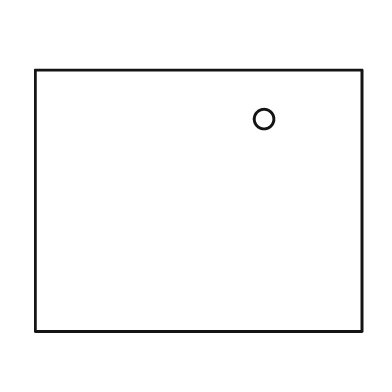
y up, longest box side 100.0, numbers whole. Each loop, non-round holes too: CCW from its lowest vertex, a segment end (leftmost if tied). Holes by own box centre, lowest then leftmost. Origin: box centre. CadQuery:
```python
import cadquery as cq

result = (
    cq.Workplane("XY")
    .moveTo(-50.0, -40.0)
    .lineTo(50.0, -40.0)
    .lineTo(50.0, 40.0)
    .lineTo(-50.0, 40.0)
    .close()
    .moveTo(20.0, 25.0)
    .circle(3.0)
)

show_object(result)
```